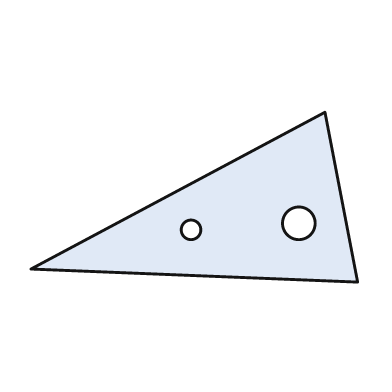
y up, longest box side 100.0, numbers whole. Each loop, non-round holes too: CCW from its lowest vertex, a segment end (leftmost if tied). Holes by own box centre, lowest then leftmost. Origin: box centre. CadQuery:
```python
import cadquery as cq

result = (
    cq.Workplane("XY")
    .moveTo(50.0, -26.0)
    .lineTo(40.0, 26.0)
    .lineTo(-50.0, -22.0)
    .close()
    .moveTo(-1.0, -10.0)
    .circle(3.0)
    .moveTo(32.0, -8.0)
    .circle(5.0)
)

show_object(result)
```